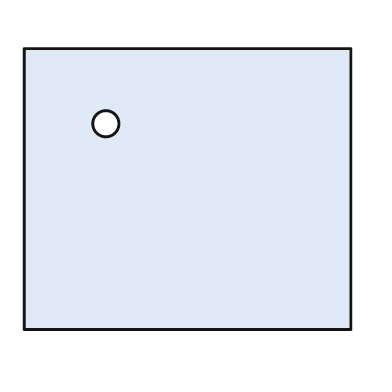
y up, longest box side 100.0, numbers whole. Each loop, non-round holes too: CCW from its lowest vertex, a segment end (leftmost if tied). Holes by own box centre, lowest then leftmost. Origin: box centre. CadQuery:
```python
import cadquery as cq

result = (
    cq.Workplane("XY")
    .moveTo(-50.0, -43.0)
    .lineTo(50.0, -43.0)
    .lineTo(50.0, 43.0)
    .lineTo(-50.0, 43.0)
    .close()
    .moveTo(-25.0, 20.0)
    .circle(4.0)
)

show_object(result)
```